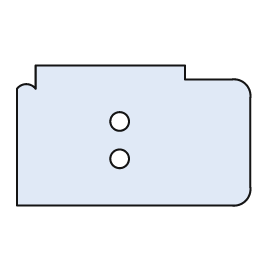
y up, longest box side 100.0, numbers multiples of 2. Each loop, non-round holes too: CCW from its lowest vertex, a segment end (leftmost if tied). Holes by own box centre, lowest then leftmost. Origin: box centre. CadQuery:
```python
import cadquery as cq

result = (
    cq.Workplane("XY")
    .moveTo(-50.0, -30.0)
    .lineTo(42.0, -30.0)
    .threePointArc((48.0, -28.0), (50.0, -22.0))
    .lineTo(50.0, 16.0)
    .threePointArc((48.0, 22.0), (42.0, 24.0))
    .lineTo(22.0, 24.0)
    .lineTo(22.0, 30.0)
    .lineTo(-42.0, 30.0)
    .lineTo(-42.0, 20.0)
    .threePointArc((-46.0, 22.0), (-50.0, 20.0))
    .close()
    .moveTo(-6.0, -10.0)
    .circle(4.0)
    .moveTo(-6.0, 6.0)
    .circle(4.0)
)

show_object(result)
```